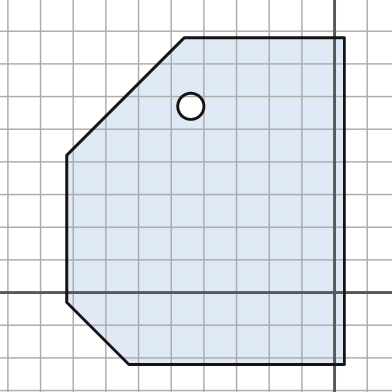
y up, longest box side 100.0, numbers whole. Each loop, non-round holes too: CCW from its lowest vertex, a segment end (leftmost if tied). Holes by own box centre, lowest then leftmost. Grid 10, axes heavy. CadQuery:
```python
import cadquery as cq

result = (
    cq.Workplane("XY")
    .moveTo(-63.0, -22.0)
    .lineTo(3.0, -22.0)
    .lineTo(3.0, 78.0)
    .lineTo(-46.0, 78.0)
    .lineTo(-82.0, 42.0)
    .lineTo(-82.0, -3.0)
    .close()
    .moveTo(-44.0, 57.0)
    .circle(4.0)
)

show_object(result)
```